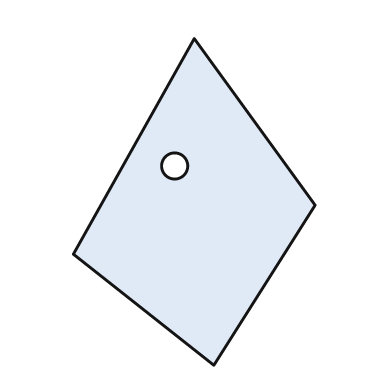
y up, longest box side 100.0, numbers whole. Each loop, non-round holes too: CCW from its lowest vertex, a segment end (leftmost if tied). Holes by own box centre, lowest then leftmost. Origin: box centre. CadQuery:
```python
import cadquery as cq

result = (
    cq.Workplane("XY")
    .moveTo(6.0, -50.0)
    .lineTo(37.0, -1.0)
    .lineTo(0.0, 50.0)
    .lineTo(-37.0, -16.0)
    .close()
    .moveTo(-6.0, 11.0)
    .circle(4.0)
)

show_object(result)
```